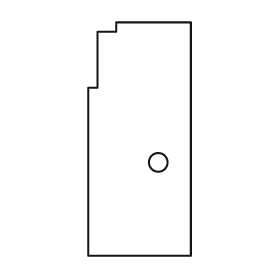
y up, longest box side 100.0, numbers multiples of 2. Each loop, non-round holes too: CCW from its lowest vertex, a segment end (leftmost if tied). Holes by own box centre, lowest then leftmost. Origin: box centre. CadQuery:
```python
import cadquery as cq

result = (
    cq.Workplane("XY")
    .moveTo(-22.0, -50.0)
    .lineTo(22.0, -50.0)
    .lineTo(22.0, 50.0)
    .lineTo(-10.0, 50.0)
    .lineTo(-10.0, 46.0)
    .lineTo(-18.0, 46.0)
    .lineTo(-18.0, 22.0)
    .lineTo(-22.0, 22.0)
    .close()
    .moveTo(8.0, -10.0)
    .circle(4.0)
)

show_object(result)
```